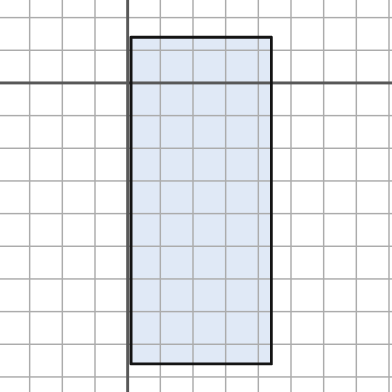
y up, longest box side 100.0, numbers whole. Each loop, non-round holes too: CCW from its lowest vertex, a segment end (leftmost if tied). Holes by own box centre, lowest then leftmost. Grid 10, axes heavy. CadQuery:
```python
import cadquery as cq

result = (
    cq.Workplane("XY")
    .moveTo(1.0, -86.0)
    .lineTo(44.0, -86.0)
    .lineTo(44.0, 14.0)
    .lineTo(1.0, 14.0)
    .close()
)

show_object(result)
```